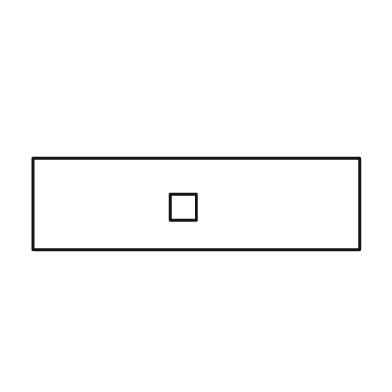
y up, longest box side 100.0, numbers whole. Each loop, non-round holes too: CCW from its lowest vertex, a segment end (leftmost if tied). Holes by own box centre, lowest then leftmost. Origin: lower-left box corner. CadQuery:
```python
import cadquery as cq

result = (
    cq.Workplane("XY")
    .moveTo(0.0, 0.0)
    .lineTo(100.0, 0.0)
    .lineTo(100.0, 28.0)
    .lineTo(0.0, 28.0)
    .close()
    .moveTo(42.0, 9.0)
    .lineTo(50.0, 9.0)
    .lineTo(50.0, 17.0)
    .lineTo(42.0, 17.0)
    .close()
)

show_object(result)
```